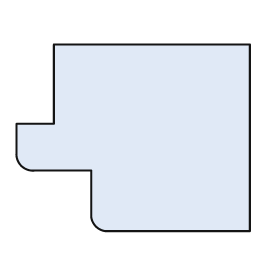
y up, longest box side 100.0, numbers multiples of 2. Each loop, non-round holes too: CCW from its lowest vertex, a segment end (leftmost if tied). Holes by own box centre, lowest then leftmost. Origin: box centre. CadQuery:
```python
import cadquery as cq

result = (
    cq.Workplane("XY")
    .moveTo(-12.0, -40.0)
    .lineTo(50.0, -40.0)
    .lineTo(50.0, 40.0)
    .lineTo(-34.0, 40.0)
    .lineTo(-34.0, 6.0)
    .lineTo(-50.0, 6.0)
    .lineTo(-50.0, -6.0)
    .threePointArc((-48.0, -12.0), (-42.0, -14.0))
    .lineTo(-18.0, -14.0)
    .lineTo(-18.0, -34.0)
    .threePointArc((-16.0, -38.0), (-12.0, -40.0))
    .close()
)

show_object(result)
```